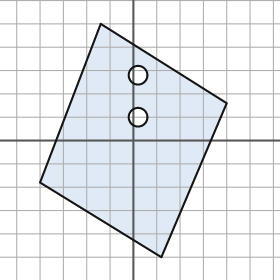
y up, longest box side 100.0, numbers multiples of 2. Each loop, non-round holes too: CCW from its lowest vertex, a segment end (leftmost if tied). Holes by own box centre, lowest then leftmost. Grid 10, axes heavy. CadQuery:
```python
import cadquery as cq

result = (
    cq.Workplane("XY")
    .moveTo(12.0, -50.0)
    .lineTo(40.0, 16.0)
    .lineTo(-14.0, 50.0)
    .lineTo(-40.0, -18.0)
    .close()
    .moveTo(2.0, 10.0)
    .circle(4.0)
    .moveTo(2.0, 28.0)
    .circle(4.0)
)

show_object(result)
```